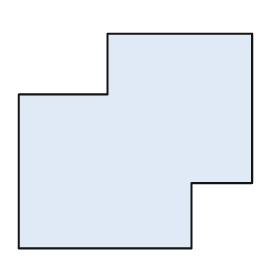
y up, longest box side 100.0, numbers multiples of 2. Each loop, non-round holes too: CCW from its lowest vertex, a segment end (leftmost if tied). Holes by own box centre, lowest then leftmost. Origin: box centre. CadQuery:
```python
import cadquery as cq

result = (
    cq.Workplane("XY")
    .moveTo(-50.0, -46.0)
    .lineTo(24.0, -46.0)
    .lineTo(24.0, -18.0)
    .lineTo(50.0, -18.0)
    .lineTo(50.0, 46.0)
    .lineTo(-12.0, 46.0)
    .lineTo(-12.0, 20.0)
    .lineTo(-50.0, 20.0)
    .close()
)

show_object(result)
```